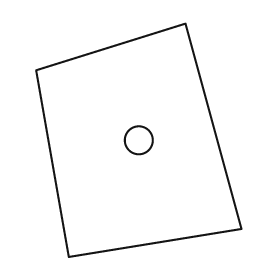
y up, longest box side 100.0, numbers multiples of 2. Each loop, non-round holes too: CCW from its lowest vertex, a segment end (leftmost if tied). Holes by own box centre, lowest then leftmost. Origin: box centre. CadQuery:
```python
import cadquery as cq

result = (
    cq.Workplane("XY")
    .moveTo(-30.0, -50.0)
    .lineTo(44.0, -38.0)
    .lineTo(20.0, 50.0)
    .lineTo(-44.0, 30.0)
    .close()
    .moveTo(0.0, 0.0)
    .circle(6.0)
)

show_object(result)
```